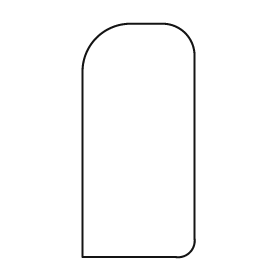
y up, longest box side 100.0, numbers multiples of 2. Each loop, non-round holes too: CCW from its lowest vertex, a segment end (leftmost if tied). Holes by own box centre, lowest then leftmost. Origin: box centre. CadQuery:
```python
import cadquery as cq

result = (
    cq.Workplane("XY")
    .moveTo(-24.0, -50.0)
    .lineTo(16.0, -50.0)
    .threePointArc((22.0, -48.0), (24.0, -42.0))
    .lineTo(24.0, 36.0)
    .threePointArc((20.0, 46.0), (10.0, 50.0))
    .lineTo(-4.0, 50.0)
    .threePointArc((-18.0, 44.0), (-24.0, 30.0))
    .close()
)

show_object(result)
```